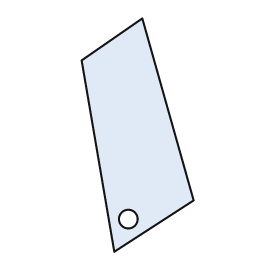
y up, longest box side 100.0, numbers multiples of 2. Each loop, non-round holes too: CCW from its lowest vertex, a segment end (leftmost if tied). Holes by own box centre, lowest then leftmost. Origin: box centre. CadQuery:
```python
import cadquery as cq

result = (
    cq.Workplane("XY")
    .moveTo(-10.0, -50.0)
    .lineTo(24.0, -28.0)
    .lineTo(2.0, 50.0)
    .lineTo(-24.0, 32.0)
    .close()
    .moveTo(-4.0, -36.0)
    .circle(4.0)
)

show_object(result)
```